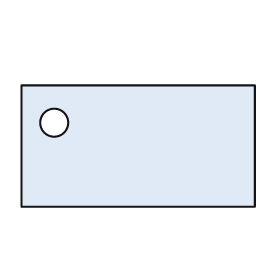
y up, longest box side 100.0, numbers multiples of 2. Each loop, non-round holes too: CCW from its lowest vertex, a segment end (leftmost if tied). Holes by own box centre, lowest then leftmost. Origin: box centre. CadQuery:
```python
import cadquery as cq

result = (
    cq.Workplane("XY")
    .moveTo(-50.0, -26.0)
    .lineTo(50.0, -26.0)
    .lineTo(50.0, 26.0)
    .lineTo(-50.0, 26.0)
    .close()
    .moveTo(-36.0, 10.0)
    .circle(6.0)
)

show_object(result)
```